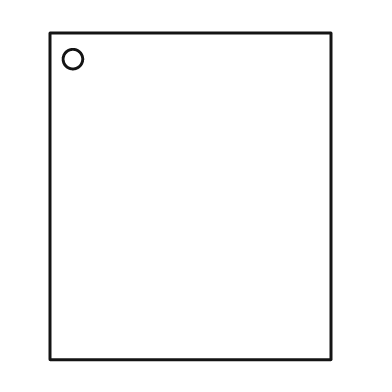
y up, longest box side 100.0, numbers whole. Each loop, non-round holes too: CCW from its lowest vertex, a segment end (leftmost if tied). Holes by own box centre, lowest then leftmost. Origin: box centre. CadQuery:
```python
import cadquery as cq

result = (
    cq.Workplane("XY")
    .moveTo(-43.0, -50.0)
    .lineTo(43.0, -50.0)
    .lineTo(43.0, 50.0)
    .lineTo(-43.0, 50.0)
    .close()
    .moveTo(-36.0, 42.0)
    .circle(3.0)
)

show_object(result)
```